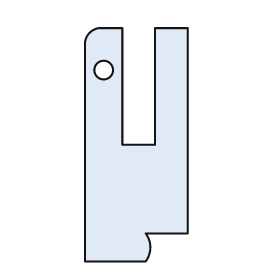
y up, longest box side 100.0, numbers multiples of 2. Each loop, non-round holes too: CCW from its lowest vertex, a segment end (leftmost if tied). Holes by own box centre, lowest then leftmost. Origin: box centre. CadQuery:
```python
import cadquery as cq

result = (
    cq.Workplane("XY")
    .moveTo(-22.0, -50.0)
    .lineTo(4.0, -50.0)
    .threePointArc((6.0, -44.0), (4.0, -38.0))
    .lineTo(22.0, -38.0)
    .lineTo(22.0, 50.0)
    .lineTo(8.0, 50.0)
    .lineTo(8.0, 0.0)
    .lineTo(-6.0, 0.0)
    .lineTo(-6.0, 50.0)
    .lineTo(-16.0, 50.0)
    .threePointArc((-20.0, 48.0), (-22.0, 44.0))
    .close()
    .moveTo(-14.0, 32.0)
    .circle(4.0)
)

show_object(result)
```